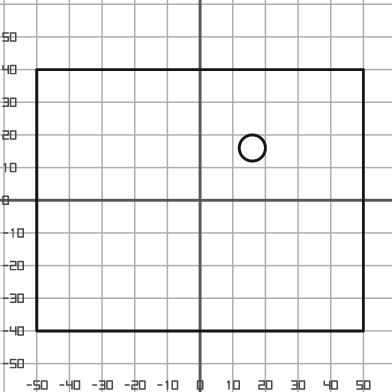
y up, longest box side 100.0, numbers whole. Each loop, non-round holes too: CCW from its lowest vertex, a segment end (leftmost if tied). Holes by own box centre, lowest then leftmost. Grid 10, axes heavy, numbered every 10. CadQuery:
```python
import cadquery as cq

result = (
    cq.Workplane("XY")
    .moveTo(-50.0, -40.0)
    .lineTo(50.0, -40.0)
    .lineTo(50.0, 40.0)
    .lineTo(-50.0, 40.0)
    .close()
    .moveTo(16.0, 16.0)
    .circle(4.0)
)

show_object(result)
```